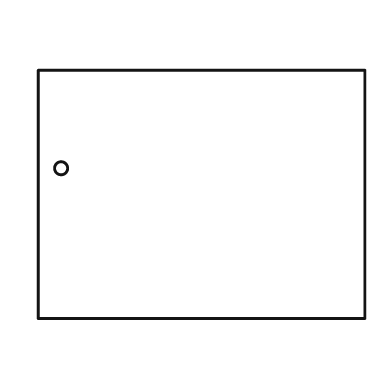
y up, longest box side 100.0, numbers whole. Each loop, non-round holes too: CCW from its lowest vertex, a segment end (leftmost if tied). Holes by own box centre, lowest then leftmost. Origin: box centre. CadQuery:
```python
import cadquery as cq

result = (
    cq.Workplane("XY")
    .moveTo(-50.0, -38.0)
    .lineTo(50.0, -38.0)
    .lineTo(50.0, 38.0)
    .lineTo(-50.0, 38.0)
    .close()
    .moveTo(-43.0, 8.0)
    .circle(2.0)
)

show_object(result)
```